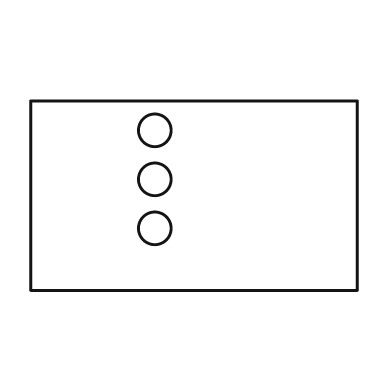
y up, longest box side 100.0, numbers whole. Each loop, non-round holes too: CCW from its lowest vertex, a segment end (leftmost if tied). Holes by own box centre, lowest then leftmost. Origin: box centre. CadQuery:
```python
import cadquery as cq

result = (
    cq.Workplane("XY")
    .moveTo(-50.0, -29.0)
    .lineTo(50.0, -29.0)
    .lineTo(50.0, 29.0)
    .lineTo(-50.0, 29.0)
    .close()
    .moveTo(-12.0, -10.0)
    .circle(5.0)
    .moveTo(-12.0, 5.0)
    .circle(5.0)
    .moveTo(-12.0, 20.0)
    .circle(5.0)
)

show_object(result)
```